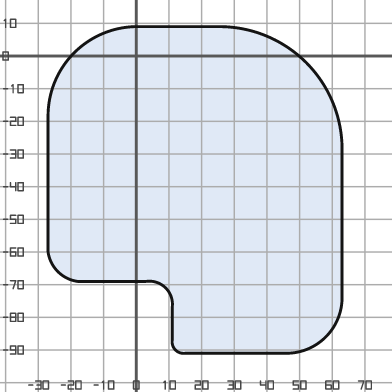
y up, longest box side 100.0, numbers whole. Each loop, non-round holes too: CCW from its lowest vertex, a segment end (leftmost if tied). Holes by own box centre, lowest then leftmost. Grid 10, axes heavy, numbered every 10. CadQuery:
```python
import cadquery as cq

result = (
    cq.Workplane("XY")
    .moveTo(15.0, -91.0)
    .lineTo(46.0, -91.0)
    .threePointArc((58.0, -86.0), (63.0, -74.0))
    .lineTo(63.0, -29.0)
    .threePointArc((52.0, -2.0), (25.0, 9.0))
    .lineTo(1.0, 9.0)
    .threePointArc((-19.0, 1.0), (-27.0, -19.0))
    .lineTo(-27.0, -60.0)
    .threePointArc((-24.0, -66.0), (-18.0, -69.0))
    .lineTo(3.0, -69.0)
    .threePointArc((9.0, -71.0), (11.0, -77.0))
    .lineTo(11.0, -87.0)
    .threePointArc((12.0, -90.0), (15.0, -91.0))
    .close()
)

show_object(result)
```